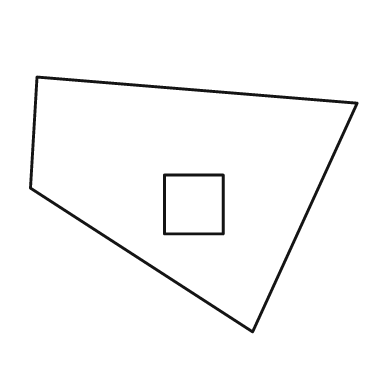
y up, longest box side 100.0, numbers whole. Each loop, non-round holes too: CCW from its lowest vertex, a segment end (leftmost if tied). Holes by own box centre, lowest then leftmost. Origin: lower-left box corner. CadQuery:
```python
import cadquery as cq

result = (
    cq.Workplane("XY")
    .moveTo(68.0, 0.0)
    .lineTo(100.0, 70.0)
    .lineTo(2.0, 78.0)
    .lineTo(0.0, 44.0)
    .close()
    .moveTo(41.0, 30.0)
    .lineTo(59.0, 30.0)
    .lineTo(59.0, 48.0)
    .lineTo(41.0, 48.0)
    .close()
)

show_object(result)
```